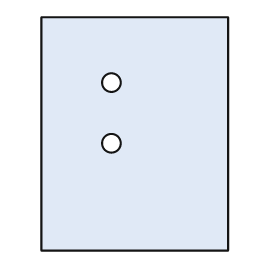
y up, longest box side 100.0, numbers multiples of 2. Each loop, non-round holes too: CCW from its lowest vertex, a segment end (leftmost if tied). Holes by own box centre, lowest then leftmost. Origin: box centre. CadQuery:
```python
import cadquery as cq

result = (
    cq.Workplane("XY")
    .moveTo(-40.0, -50.0)
    .lineTo(40.0, -50.0)
    .lineTo(40.0, 50.0)
    .lineTo(-40.0, 50.0)
    .close()
    .moveTo(-10.0, -4.0)
    .circle(4.0)
    .moveTo(-10.0, 22.0)
    .circle(4.0)
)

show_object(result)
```